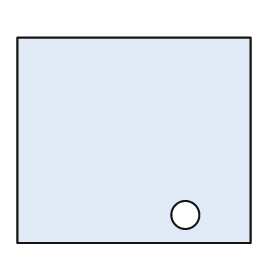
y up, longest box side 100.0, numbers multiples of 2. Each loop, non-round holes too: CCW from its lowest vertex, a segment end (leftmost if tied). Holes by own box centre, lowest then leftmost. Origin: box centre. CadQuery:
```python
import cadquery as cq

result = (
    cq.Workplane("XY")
    .moveTo(-50.0, -44.0)
    .lineTo(50.0, -44.0)
    .lineTo(50.0, 44.0)
    .lineTo(-50.0, 44.0)
    .close()
    .moveTo(22.0, -32.0)
    .circle(6.0)
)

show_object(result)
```